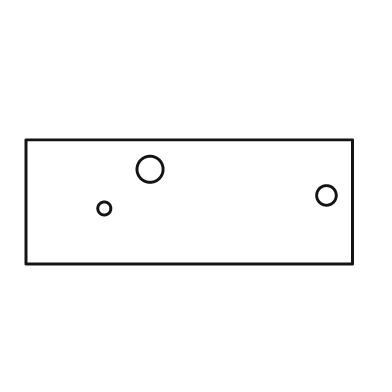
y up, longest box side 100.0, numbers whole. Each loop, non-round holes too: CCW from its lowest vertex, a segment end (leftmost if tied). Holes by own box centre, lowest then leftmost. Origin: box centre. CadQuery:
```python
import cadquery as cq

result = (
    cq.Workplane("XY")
    .moveTo(-50.0, -19.0)
    .lineTo(50.0, -19.0)
    .lineTo(50.0, 19.0)
    .lineTo(-50.0, 19.0)
    .close()
    .moveTo(-26.0, -2.0)
    .circle(2.0)
    .moveTo(42.0, 2.0)
    .circle(3.0)
    .moveTo(-12.0, 10.0)
    .circle(4.0)
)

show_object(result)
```